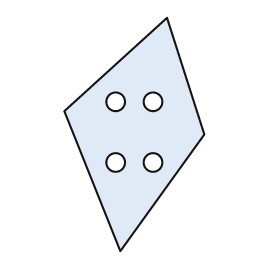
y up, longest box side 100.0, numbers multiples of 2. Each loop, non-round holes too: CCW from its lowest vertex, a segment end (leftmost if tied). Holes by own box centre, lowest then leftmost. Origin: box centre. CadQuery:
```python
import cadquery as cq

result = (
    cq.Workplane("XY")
    .moveTo(-6.0, -50.0)
    .lineTo(30.0, 0.0)
    .lineTo(14.0, 50.0)
    .lineTo(-30.0, 10.0)
    .close()
    .moveTo(-8.0, -12.0)
    .circle(4.0)
    .moveTo(8.0, -12.0)
    .circle(4.0)
    .moveTo(-8.0, 14.0)
    .circle(4.0)
    .moveTo(8.0, 14.0)
    .circle(4.0)
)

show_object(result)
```